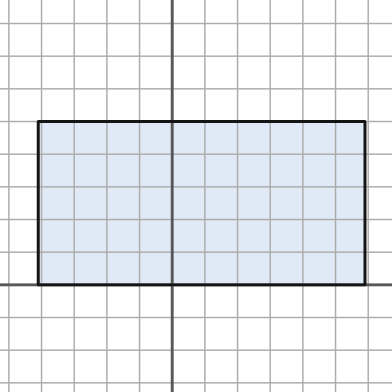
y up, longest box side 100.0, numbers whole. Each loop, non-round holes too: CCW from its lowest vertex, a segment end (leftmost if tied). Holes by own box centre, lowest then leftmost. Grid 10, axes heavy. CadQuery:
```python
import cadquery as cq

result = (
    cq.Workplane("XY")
    .moveTo(-41.0, 0.0)
    .lineTo(59.0, 0.0)
    .lineTo(59.0, 50.0)
    .lineTo(-41.0, 50.0)
    .close()
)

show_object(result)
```